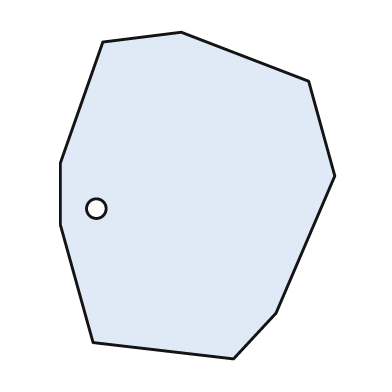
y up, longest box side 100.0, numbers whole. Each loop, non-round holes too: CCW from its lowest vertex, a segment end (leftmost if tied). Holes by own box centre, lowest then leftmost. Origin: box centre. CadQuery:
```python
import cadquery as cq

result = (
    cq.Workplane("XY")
    .moveTo(11.0, -50.0)
    .lineTo(24.0, -36.0)
    .lineTo(42.0, 6.0)
    .lineTo(34.0, 35.0)
    .lineTo(-5.0, 50.0)
    .lineTo(-29.0, 47.0)
    .lineTo(-42.0, 10.0)
    .lineTo(-42.0, -9.0)
    .lineTo(-32.0, -45.0)
    .close()
    .moveTo(-31.0, -4.0)
    .circle(3.0)
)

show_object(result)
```